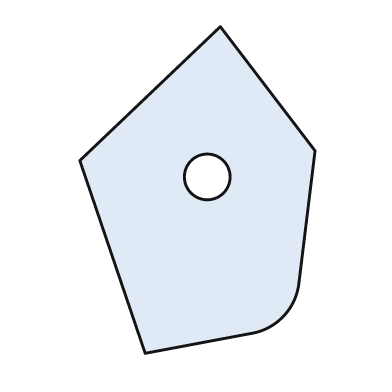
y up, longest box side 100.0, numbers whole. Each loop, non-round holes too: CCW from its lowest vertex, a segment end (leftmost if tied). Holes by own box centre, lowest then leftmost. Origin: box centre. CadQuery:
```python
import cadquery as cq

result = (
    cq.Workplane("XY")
    .moveTo(-16.0, -50.0)
    .lineTo(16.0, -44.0)
    .threePointArc((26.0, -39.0), (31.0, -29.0))
    .lineTo(36.0, 12.0)
    .lineTo(7.0, 50.0)
    .lineTo(-36.0, 9.0)
    .close()
    .moveTo(3.0, 4.0)
    .circle(7.0)
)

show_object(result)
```